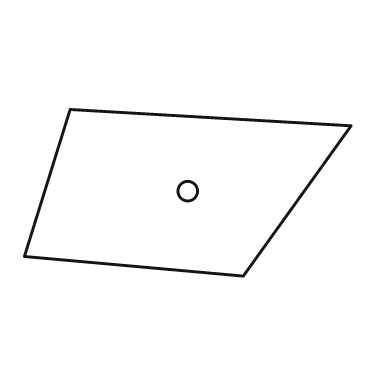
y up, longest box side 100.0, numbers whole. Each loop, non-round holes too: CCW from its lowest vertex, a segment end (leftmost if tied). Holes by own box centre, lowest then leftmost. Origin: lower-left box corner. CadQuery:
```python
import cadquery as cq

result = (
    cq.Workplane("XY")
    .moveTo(67.0, 0.0)
    .lineTo(100.0, 46.0)
    .lineTo(14.0, 51.0)
    .lineTo(0.0, 6.0)
    .close()
    .moveTo(50.0, 26.0)
    .circle(3.0)
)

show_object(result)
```